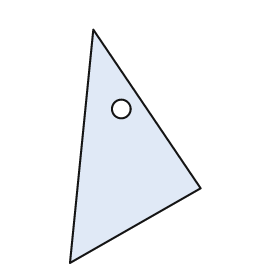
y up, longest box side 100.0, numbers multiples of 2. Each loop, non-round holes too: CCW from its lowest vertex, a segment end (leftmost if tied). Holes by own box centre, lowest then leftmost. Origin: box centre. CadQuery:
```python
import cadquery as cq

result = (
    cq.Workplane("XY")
    .moveTo(-28.0, -50.0)
    .lineTo(28.0, -18.0)
    .lineTo(-18.0, 50.0)
    .close()
    .moveTo(-6.0, 16.0)
    .circle(4.0)
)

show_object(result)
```